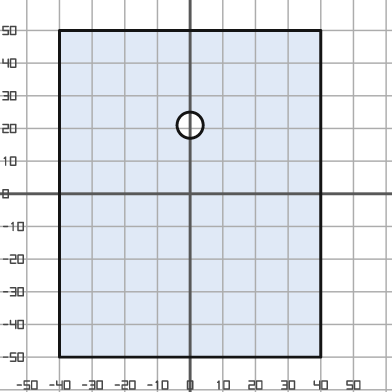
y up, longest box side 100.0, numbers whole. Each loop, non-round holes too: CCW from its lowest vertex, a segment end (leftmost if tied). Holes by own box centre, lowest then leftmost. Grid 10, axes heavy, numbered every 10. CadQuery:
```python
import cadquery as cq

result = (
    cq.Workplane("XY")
    .moveTo(-40.0, -50.0)
    .lineTo(40.0, -50.0)
    .lineTo(40.0, 50.0)
    .lineTo(-40.0, 50.0)
    .close()
    .moveTo(0.0, 21.0)
    .circle(4.0)
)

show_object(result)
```